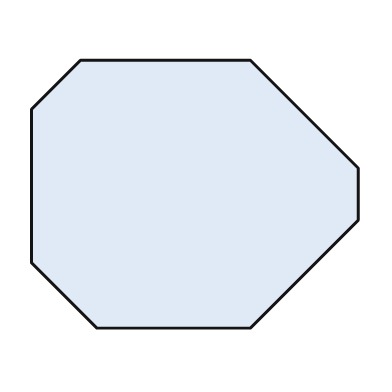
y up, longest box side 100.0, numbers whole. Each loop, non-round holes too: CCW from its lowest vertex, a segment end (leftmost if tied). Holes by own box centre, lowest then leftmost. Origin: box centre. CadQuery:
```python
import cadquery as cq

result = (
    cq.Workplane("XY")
    .moveTo(-30.0, -41.0)
    .lineTo(17.0, -41.0)
    .lineTo(50.0, -8.0)
    .lineTo(50.0, 8.0)
    .lineTo(17.0, 41.0)
    .lineTo(-35.0, 41.0)
    .lineTo(-50.0, 26.0)
    .lineTo(-50.0, -21.0)
    .close()
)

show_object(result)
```